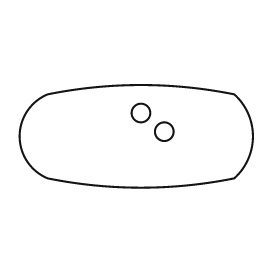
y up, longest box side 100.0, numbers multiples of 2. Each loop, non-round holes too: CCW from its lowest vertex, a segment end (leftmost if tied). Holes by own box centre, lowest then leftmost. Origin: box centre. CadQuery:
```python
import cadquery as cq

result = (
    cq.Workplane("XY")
    .moveTo(-38.0, -18.0)
    .threePointArc((2.0, -22.0), (42.0, -18.0))
    .threePointArc((50.0, 0.0), (42.0, 18.0))
    .threePointArc((2.0, 22.0), (-38.0, 18.0))
    .threePointArc((-50.0, 0.0), (-38.0, -18.0))
    .close()
    .moveTo(12.0, 2.0)
    .circle(4.0)
    .moveTo(2.0, 10.0)
    .circle(4.0)
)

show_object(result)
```